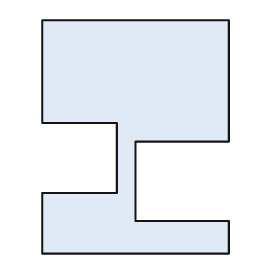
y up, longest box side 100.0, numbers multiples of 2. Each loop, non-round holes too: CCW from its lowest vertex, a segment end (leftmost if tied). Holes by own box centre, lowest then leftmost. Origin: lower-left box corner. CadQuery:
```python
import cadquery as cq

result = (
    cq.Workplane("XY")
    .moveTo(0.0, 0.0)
    .lineTo(80.0, 0.0)
    .lineTo(80.0, 14.0)
    .lineTo(40.0, 14.0)
    .lineTo(40.0, 48.0)
    .lineTo(80.0, 48.0)
    .lineTo(80.0, 100.0)
    .lineTo(0.0, 100.0)
    .lineTo(0.0, 56.0)
    .lineTo(32.0, 56.0)
    .lineTo(32.0, 26.0)
    .lineTo(0.0, 26.0)
    .close()
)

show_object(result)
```